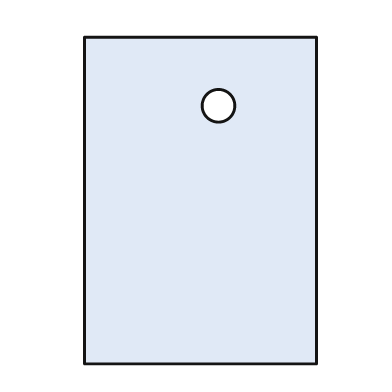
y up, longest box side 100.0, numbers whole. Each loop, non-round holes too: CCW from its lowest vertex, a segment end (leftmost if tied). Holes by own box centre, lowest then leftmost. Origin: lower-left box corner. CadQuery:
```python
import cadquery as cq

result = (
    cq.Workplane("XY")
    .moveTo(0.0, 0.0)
    .lineTo(71.0, 0.0)
    .lineTo(71.0, 100.0)
    .lineTo(0.0, 100.0)
    .close()
    .moveTo(41.0, 79.0)
    .circle(5.0)
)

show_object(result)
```